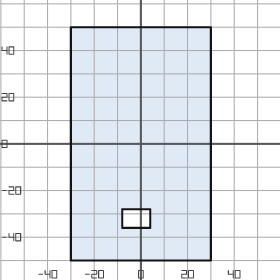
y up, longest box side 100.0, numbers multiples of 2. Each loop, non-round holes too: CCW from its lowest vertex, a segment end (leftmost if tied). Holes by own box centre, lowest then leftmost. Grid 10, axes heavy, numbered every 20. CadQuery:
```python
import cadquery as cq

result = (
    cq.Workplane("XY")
    .moveTo(-30.0, -50.0)
    .lineTo(30.0, -50.0)
    .lineTo(30.0, 50.0)
    .lineTo(-30.0, 50.0)
    .close()
    .moveTo(-8.0, -36.0)
    .lineTo(4.0, -36.0)
    .lineTo(4.0, -28.0)
    .lineTo(-8.0, -28.0)
    .close()
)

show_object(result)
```